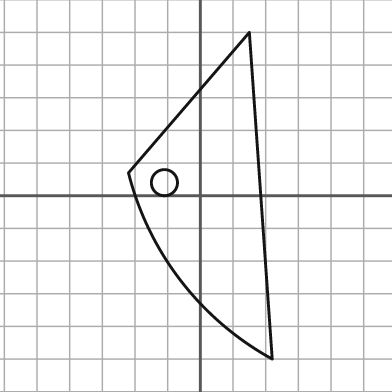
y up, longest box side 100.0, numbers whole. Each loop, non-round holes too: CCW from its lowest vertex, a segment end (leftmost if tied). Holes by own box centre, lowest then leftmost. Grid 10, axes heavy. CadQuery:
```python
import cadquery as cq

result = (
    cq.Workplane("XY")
    .moveTo(22.0, -50.0)
    .lineTo(15.0, 50.0)
    .lineTo(-22.0, 7.0)
    .threePointArc((-6.0, -26.0), (22.0, -50.0))
    .close()
    .moveTo(-11.0, 4.0)
    .circle(4.0)
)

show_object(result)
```